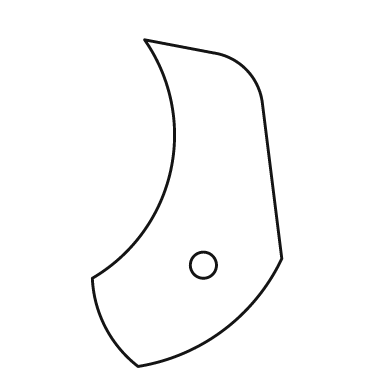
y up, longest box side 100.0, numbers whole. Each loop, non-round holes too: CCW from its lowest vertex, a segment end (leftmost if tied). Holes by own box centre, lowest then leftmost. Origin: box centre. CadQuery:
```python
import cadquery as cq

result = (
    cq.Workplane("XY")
    .moveTo(-15.0, -50.0)
    .threePointArc((11.0, -39.0), (29.0, -17.0))
    .lineTo(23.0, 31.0)
    .threePointArc((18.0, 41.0), (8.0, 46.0))
    .lineTo(-13.0, 50.0)
    .threePointArc((-5.0, 10.0), (-29.0, -23.0))
    .threePointArc((-25.0, -38.0), (-15.0, -50.0))
    .close()
    .moveTo(5.0, -19.0)
    .circle(4.0)
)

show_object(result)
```